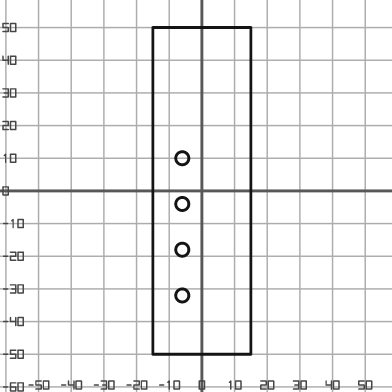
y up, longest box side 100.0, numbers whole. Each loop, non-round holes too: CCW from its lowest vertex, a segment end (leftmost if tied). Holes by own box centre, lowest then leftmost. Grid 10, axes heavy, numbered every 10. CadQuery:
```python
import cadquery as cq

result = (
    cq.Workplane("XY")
    .moveTo(-15.0, -50.0)
    .lineTo(15.0, -50.0)
    .lineTo(15.0, 50.0)
    .lineTo(-15.0, 50.0)
    .close()
    .moveTo(-6.0, -32.0)
    .circle(2.0)
    .moveTo(-6.0, -18.0)
    .circle(2.0)
    .moveTo(-6.0, -4.0)
    .circle(2.0)
    .moveTo(-6.0, 10.0)
    .circle(2.0)
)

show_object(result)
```